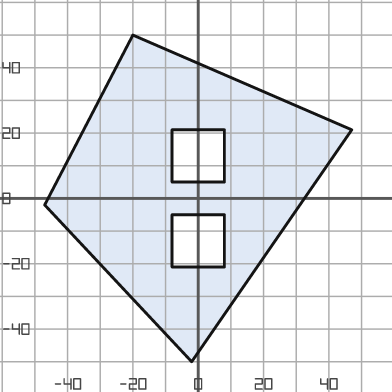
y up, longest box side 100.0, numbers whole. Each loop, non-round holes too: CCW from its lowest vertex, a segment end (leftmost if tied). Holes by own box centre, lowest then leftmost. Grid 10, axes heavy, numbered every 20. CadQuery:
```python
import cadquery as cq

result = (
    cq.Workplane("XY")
    .moveTo(-2.0, -50.0)
    .lineTo(47.0, 21.0)
    .lineTo(-20.0, 50.0)
    .lineTo(-47.0, -2.0)
    .close()
    .moveTo(-8.0, -21.0)
    .lineTo(8.0, -21.0)
    .lineTo(8.0, -5.0)
    .lineTo(-8.0, -5.0)
    .close()
    .moveTo(-8.0, 5.0)
    .lineTo(8.0, 5.0)
    .lineTo(8.0, 21.0)
    .lineTo(-8.0, 21.0)
    .close()
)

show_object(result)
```